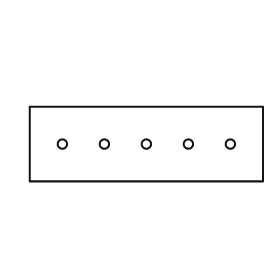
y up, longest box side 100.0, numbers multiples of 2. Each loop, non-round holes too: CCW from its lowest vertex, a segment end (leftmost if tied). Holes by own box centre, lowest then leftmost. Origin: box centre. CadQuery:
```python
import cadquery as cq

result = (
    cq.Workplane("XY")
    .moveTo(-50.0, -16.0)
    .lineTo(50.0, -16.0)
    .lineTo(50.0, 16.0)
    .lineTo(-50.0, 16.0)
    .close()
    .moveTo(-36.0, 0.0)
    .circle(2.0)
    .moveTo(-18.0, 0.0)
    .circle(2.0)
    .moveTo(0.0, 0.0)
    .circle(2.0)
    .moveTo(18.0, 0.0)
    .circle(2.0)
    .moveTo(36.0, 0.0)
    .circle(2.0)
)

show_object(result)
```